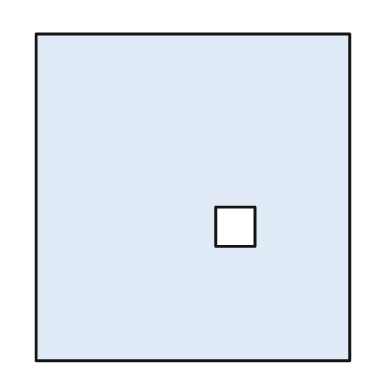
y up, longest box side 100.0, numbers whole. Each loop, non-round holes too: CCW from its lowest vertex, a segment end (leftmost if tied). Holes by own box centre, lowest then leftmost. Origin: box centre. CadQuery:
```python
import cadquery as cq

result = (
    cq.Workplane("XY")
    .moveTo(-48.0, -50.0)
    .lineTo(48.0, -50.0)
    .lineTo(48.0, 50.0)
    .lineTo(-48.0, 50.0)
    .close()
    .moveTo(7.0, -15.0)
    .lineTo(19.0, -15.0)
    .lineTo(19.0, -3.0)
    .lineTo(7.0, -3.0)
    .close()
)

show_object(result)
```